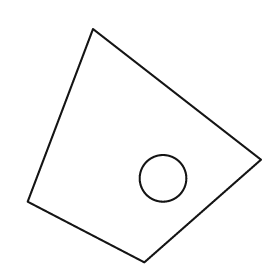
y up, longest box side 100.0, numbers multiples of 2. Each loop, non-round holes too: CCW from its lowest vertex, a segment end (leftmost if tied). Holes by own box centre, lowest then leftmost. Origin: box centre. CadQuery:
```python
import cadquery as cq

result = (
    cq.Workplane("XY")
    .moveTo(0.0, -50.0)
    .lineTo(50.0, -6.0)
    .lineTo(-22.0, 50.0)
    .lineTo(-50.0, -24.0)
    .close()
    .moveTo(8.0, -14.0)
    .circle(10.0)
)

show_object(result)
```